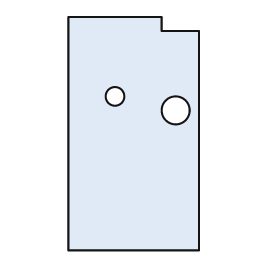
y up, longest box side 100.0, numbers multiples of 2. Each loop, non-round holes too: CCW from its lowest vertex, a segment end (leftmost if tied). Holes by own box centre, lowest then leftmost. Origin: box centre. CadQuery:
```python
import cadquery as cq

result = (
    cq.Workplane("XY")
    .moveTo(-28.0, -50.0)
    .lineTo(28.0, -50.0)
    .lineTo(28.0, 44.0)
    .lineTo(12.0, 44.0)
    .lineTo(12.0, 50.0)
    .lineTo(-28.0, 50.0)
    .close()
    .moveTo(18.0, 10.0)
    .circle(6.0)
    .moveTo(-8.0, 16.0)
    .circle(4.0)
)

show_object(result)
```